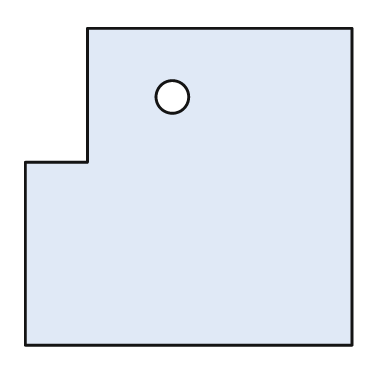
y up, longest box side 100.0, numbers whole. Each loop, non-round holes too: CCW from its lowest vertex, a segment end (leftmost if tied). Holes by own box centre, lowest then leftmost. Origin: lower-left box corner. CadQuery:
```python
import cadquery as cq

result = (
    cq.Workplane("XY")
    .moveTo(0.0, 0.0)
    .lineTo(100.0, 0.0)
    .lineTo(100.0, 97.0)
    .lineTo(19.0, 97.0)
    .lineTo(19.0, 56.0)
    .lineTo(0.0, 56.0)
    .close()
    .moveTo(45.0, 76.0)
    .circle(5.0)
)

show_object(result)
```